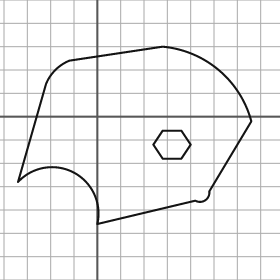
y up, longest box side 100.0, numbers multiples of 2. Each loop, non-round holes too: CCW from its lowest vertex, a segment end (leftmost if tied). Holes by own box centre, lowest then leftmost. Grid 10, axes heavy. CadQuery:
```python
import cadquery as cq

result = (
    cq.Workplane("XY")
    .moveTo(0.0, -46.0)
    .lineTo(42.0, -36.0)
    .threePointArc((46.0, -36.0), (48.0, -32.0))
    .lineTo(66.0, -2.0)
    .threePointArc((52.0, 20.0), (28.0, 30.0))
    .lineTo(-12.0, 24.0)
    .threePointArc((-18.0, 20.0), (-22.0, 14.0))
    .lineTo(-34.0, -28.0)
    .threePointArc((-10.0, -24.0), (0.0, -46.0))
    .close()
    .moveTo(28.0, -18.0)
    .lineTo(36.0, -18.0)
    .lineTo(40.0, -12.0)
    .lineTo(36.0, -6.0)
    .lineTo(28.0, -6.0)
    .lineTo(24.0, -12.0)
    .close()
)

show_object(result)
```